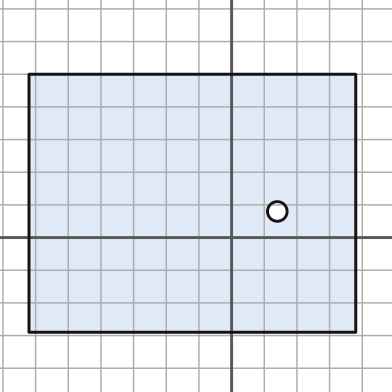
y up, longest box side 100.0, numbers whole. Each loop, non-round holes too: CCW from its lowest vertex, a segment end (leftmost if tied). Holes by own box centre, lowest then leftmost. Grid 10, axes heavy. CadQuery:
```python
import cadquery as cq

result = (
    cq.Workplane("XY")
    .moveTo(-62.0, -29.0)
    .lineTo(38.0, -29.0)
    .lineTo(38.0, 50.0)
    .lineTo(-62.0, 50.0)
    .close()
    .moveTo(14.0, 8.0)
    .circle(3.0)
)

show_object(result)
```